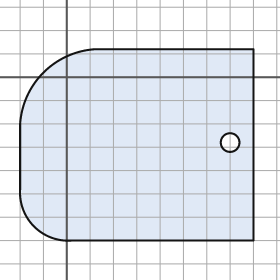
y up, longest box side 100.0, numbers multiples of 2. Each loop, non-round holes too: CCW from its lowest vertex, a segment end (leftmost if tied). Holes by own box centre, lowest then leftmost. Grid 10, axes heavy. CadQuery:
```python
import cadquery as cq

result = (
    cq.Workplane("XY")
    .moveTo(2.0, -70.0)
    .lineTo(80.0, -70.0)
    .lineTo(80.0, 12.0)
    .lineTo(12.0, 12.0)
    .threePointArc((-10.0, 2.0), (-20.0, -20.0))
    .lineTo(-20.0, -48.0)
    .threePointArc((-14.0, -64.0), (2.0, -70.0))
    .close()
    .moveTo(70.0, -28.0)
    .circle(4.0)
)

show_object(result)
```